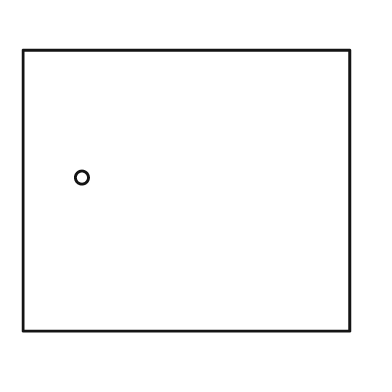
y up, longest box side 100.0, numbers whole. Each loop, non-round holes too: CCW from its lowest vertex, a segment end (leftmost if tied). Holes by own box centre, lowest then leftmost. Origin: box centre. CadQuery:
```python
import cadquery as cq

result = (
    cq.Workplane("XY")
    .moveTo(-50.0, -43.0)
    .lineTo(50.0, -43.0)
    .lineTo(50.0, 43.0)
    .lineTo(-50.0, 43.0)
    .close()
    .moveTo(-32.0, 4.0)
    .circle(2.0)
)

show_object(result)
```